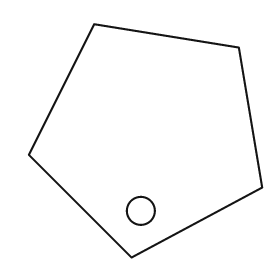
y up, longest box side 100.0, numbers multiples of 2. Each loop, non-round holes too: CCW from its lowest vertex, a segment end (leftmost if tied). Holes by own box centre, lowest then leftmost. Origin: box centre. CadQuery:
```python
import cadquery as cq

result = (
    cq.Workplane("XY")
    .moveTo(-6.0, -50.0)
    .lineTo(50.0, -20.0)
    .lineTo(40.0, 40.0)
    .lineTo(-22.0, 50.0)
    .lineTo(-50.0, -6.0)
    .close()
    .moveTo(-2.0, -30.0)
    .circle(6.0)
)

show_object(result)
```